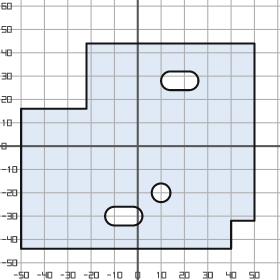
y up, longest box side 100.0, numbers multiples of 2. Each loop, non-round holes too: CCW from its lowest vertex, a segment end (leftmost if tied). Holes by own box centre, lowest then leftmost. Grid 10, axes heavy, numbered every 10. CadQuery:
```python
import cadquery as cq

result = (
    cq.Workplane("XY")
    .moveTo(-50.0, -44.0)
    .lineTo(40.0, -44.0)
    .lineTo(40.0, -32.0)
    .lineTo(50.0, -32.0)
    .lineTo(50.0, 44.0)
    .lineTo(-22.0, 44.0)
    .lineTo(-22.0, 16.0)
    .lineTo(-50.0, 16.0)
    .close()
    .moveTo(-10.0, -34.0)
    .lineTo(-2.0, -34.0)
    .threePointArc((2.0, -30.0), (-2.0, -26.0))
    .lineTo(-10.0, -26.0)
    .threePointArc((-14.0, -30.0), (-10.0, -34.0))
    .close()
    .moveTo(10.0, -20.0)
    .circle(4.0)
    .moveTo(14.0, 24.0)
    .lineTo(22.0, 24.0)
    .threePointArc((26.0, 28.0), (22.0, 32.0))
    .lineTo(14.0, 32.0)
    .threePointArc((10.0, 28.0), (14.0, 24.0))
    .close()
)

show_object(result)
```